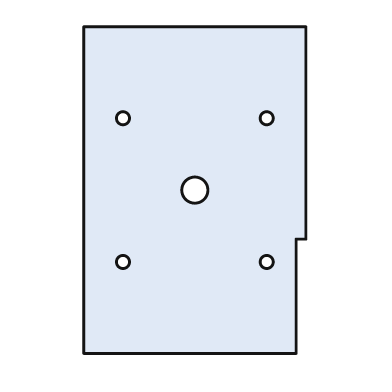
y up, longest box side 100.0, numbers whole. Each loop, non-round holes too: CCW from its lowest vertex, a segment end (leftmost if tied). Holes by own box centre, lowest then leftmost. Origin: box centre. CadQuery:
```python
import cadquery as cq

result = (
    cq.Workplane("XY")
    .moveTo(-34.0, -50.0)
    .lineTo(31.0, -50.0)
    .lineTo(31.0, -15.0)
    .lineTo(34.0, -15.0)
    .lineTo(34.0, 50.0)
    .lineTo(-34.0, 50.0)
    .close()
    .moveTo(-22.0, -22.0)
    .circle(2.0)
    .moveTo(22.0, -22.0)
    .circle(2.0)
    .moveTo(0.0, 0.0)
    .circle(4.0)
    .moveTo(-22.0, 22.0)
    .circle(2.0)
    .moveTo(22.0, 22.0)
    .circle(2.0)
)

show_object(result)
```